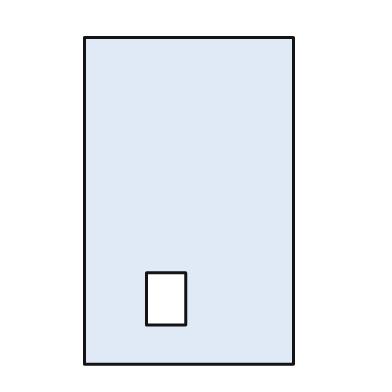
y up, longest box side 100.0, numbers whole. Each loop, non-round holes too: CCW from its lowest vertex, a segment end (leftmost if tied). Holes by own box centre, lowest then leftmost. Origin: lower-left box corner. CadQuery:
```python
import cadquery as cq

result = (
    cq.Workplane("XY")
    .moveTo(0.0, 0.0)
    .lineTo(64.0, 0.0)
    .lineTo(64.0, 100.0)
    .lineTo(0.0, 100.0)
    .close()
    .moveTo(19.0, 12.0)
    .lineTo(31.0, 12.0)
    .lineTo(31.0, 28.0)
    .lineTo(19.0, 28.0)
    .close()
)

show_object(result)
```